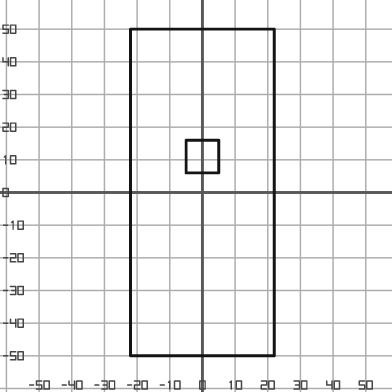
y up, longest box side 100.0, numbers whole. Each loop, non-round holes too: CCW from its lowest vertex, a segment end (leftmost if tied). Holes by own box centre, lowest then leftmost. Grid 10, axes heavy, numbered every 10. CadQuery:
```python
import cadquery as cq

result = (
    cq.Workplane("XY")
    .moveTo(-22.0, -50.0)
    .lineTo(22.0, -50.0)
    .lineTo(22.0, 50.0)
    .lineTo(-22.0, 50.0)
    .close()
    .moveTo(-5.0, 6.0)
    .lineTo(5.0, 6.0)
    .lineTo(5.0, 16.0)
    .lineTo(-5.0, 16.0)
    .close()
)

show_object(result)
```